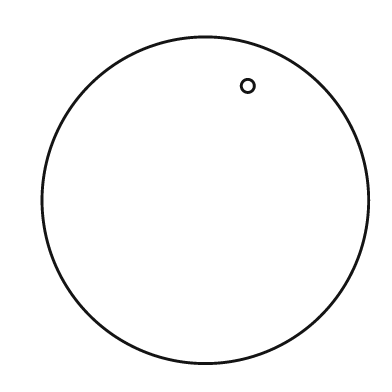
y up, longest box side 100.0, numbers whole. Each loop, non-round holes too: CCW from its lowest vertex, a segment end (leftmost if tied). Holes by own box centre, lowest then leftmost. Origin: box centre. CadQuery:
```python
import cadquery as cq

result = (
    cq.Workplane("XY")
    .moveTo(0.0, 0.0)
    .circle(50.0)
    .moveTo(13.0, 35.0)
    .circle(2.0)
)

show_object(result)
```